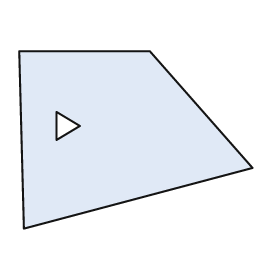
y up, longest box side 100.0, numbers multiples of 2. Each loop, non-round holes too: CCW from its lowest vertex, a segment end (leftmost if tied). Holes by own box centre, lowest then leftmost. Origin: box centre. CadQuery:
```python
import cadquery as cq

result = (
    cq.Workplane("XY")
    .moveTo(-48.0, -38.0)
    .lineTo(50.0, -12.0)
    .lineTo(6.0, 38.0)
    .lineTo(-50.0, 38.0)
    .close()
    .moveTo(-34.0, 0.0)
    .lineTo(-24.0, 6.0)
    .lineTo(-34.0, 12.0)
    .close()
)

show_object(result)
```